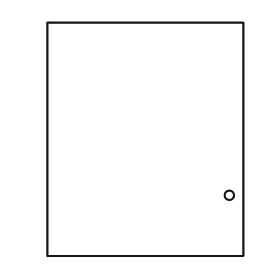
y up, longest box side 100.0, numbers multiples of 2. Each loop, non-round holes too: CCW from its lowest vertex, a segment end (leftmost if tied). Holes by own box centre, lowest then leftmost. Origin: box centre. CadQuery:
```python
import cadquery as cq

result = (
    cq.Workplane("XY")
    .moveTo(-42.0, -50.0)
    .lineTo(42.0, -50.0)
    .lineTo(42.0, 50.0)
    .lineTo(-42.0, 50.0)
    .close()
    .moveTo(36.0, -24.0)
    .circle(2.0)
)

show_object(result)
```